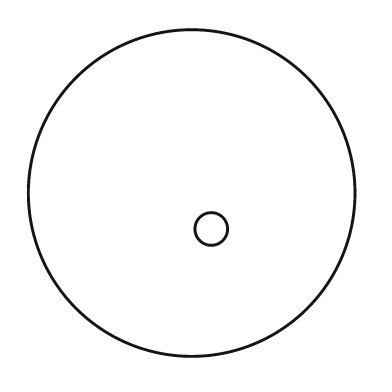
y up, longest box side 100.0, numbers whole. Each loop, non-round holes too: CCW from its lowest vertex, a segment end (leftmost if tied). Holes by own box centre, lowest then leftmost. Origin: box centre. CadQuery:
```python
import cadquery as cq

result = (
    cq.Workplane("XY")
    .moveTo(0.0, 0.0)
    .circle(50.0)
    .moveTo(6.0, -11.0)
    .circle(5.0)
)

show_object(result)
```